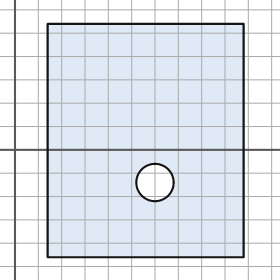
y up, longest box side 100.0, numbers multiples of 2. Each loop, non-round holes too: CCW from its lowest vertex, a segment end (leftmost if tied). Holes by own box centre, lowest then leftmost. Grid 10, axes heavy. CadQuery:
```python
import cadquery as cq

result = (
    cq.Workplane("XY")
    .moveTo(14.0, -46.0)
    .lineTo(98.0, -46.0)
    .lineTo(98.0, 54.0)
    .lineTo(14.0, 54.0)
    .close()
    .moveTo(60.0, -14.0)
    .circle(8.0)
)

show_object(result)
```